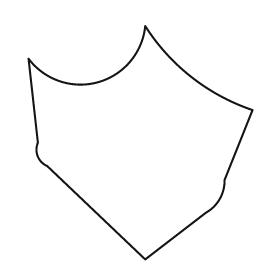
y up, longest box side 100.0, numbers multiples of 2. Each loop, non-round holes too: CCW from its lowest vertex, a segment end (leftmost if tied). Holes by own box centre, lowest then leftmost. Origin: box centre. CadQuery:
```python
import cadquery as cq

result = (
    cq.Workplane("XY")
    .moveTo(2.0, -50.0)
    .lineTo(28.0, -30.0)
    .threePointArc((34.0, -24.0), (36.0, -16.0))
    .lineTo(48.0, 14.0)
    .threePointArc((22.0, 28.0), (2.0, 50.0))
    .threePointArc((-18.0, 26.0), (-48.0, 36.0))
    .lineTo(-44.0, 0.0)
    .threePointArc((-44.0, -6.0), (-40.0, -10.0))
    .close()
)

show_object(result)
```